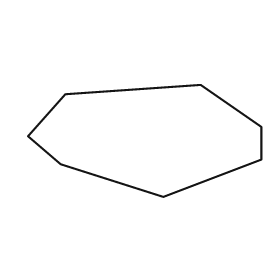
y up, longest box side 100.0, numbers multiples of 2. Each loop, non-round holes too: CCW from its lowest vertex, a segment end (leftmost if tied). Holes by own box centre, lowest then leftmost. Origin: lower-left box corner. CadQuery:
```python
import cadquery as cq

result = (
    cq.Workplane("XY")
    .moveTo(58.0, 0.0)
    .lineTo(100.0, 16.0)
    .lineTo(100.0, 30.0)
    .lineTo(74.0, 48.0)
    .lineTo(16.0, 44.0)
    .lineTo(0.0, 26.0)
    .lineTo(14.0, 14.0)
    .close()
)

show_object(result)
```